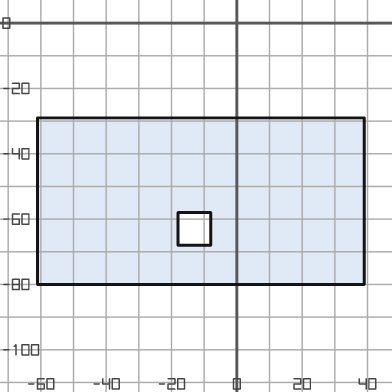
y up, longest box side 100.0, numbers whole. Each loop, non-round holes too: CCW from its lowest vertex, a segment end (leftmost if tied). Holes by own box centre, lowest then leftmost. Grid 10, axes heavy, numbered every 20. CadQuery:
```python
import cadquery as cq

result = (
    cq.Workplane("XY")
    .moveTo(-61.0, -80.0)
    .lineTo(39.0, -80.0)
    .lineTo(39.0, -29.0)
    .lineTo(-61.0, -29.0)
    .close()
    .moveTo(-18.0, -68.0)
    .lineTo(-8.0, -68.0)
    .lineTo(-8.0, -58.0)
    .lineTo(-18.0, -58.0)
    .close()
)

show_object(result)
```